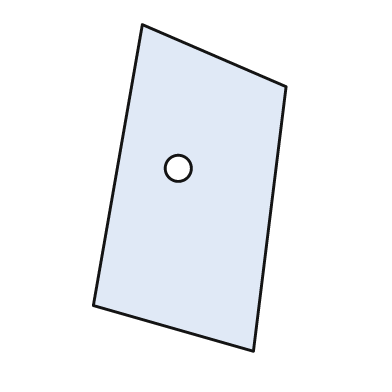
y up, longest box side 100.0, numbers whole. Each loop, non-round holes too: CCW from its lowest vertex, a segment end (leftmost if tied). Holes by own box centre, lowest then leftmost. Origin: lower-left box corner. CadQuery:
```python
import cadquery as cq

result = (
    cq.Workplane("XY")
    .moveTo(49.0, 0.0)
    .lineTo(59.0, 81.0)
    .lineTo(15.0, 100.0)
    .lineTo(0.0, 14.0)
    .close()
    .moveTo(26.0, 56.0)
    .circle(4.0)
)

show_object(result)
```